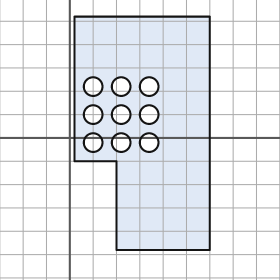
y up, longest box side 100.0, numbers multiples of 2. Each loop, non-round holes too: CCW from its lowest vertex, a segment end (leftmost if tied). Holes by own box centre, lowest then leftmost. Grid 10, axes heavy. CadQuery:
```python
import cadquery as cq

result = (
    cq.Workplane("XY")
    .moveTo(20.0, -48.0)
    .lineTo(60.0, -48.0)
    .lineTo(60.0, 52.0)
    .lineTo(2.0, 52.0)
    .lineTo(2.0, -10.0)
    .lineTo(20.0, -10.0)
    .close()
    .moveTo(10.0, -2.0)
    .circle(4.0)
    .moveTo(22.0, -2.0)
    .circle(4.0)
    .moveTo(34.0, -2.0)
    .circle(4.0)
    .moveTo(10.0, 10.0)
    .circle(4.0)
    .moveTo(22.0, 10.0)
    .circle(4.0)
    .moveTo(34.0, 10.0)
    .circle(4.0)
    .moveTo(10.0, 22.0)
    .circle(4.0)
    .moveTo(22.0, 22.0)
    .circle(4.0)
    .moveTo(34.0, 22.0)
    .circle(4.0)
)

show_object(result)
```